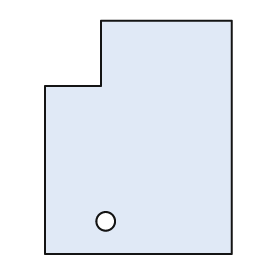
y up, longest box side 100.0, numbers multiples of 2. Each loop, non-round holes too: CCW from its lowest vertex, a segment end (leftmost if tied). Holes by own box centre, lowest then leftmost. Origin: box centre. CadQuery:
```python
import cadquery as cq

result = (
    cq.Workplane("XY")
    .moveTo(-40.0, -50.0)
    .lineTo(40.0, -50.0)
    .lineTo(40.0, 50.0)
    .lineTo(-16.0, 50.0)
    .lineTo(-16.0, 22.0)
    .lineTo(-40.0, 22.0)
    .close()
    .moveTo(-14.0, -36.0)
    .circle(4.0)
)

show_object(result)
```